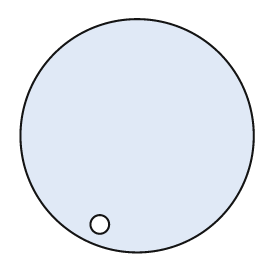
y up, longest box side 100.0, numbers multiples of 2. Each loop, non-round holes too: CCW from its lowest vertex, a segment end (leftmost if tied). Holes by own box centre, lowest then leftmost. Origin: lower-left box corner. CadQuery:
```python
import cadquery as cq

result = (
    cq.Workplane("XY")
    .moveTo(50.0, 50.0)
    .circle(50.0)
    .moveTo(34.0, 12.0)
    .circle(4.0)
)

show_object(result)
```